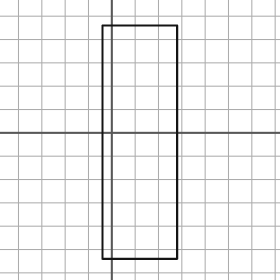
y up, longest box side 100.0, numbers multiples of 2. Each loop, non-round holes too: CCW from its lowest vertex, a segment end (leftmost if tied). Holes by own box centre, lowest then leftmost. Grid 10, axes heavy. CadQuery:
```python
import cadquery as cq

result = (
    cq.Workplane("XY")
    .moveTo(-4.0, -54.0)
    .lineTo(28.0, -54.0)
    .lineTo(28.0, 46.0)
    .lineTo(-4.0, 46.0)
    .close()
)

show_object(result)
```